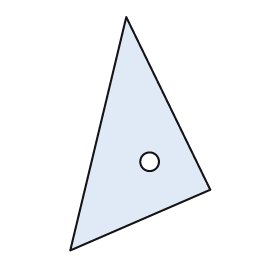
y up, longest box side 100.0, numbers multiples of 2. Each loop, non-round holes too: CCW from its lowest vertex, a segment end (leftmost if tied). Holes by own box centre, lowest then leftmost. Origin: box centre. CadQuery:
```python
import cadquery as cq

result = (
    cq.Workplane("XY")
    .moveTo(-30.0, -50.0)
    .lineTo(30.0, -24.0)
    .lineTo(-6.0, 50.0)
    .close()
    .moveTo(4.0, -12.0)
    .circle(4.0)
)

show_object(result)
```